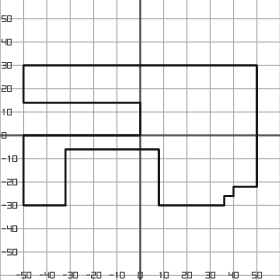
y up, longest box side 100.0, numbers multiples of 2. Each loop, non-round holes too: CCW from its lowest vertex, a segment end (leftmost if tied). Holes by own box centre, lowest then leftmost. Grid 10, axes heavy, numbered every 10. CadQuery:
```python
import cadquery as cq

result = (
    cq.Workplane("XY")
    .moveTo(-50.0, -30.0)
    .lineTo(-32.0, -30.0)
    .lineTo(-32.0, -6.0)
    .lineTo(8.0, -6.0)
    .lineTo(8.0, -30.0)
    .lineTo(36.0, -30.0)
    .lineTo(36.0, -26.0)
    .lineTo(40.0, -26.0)
    .lineTo(40.0, -22.0)
    .lineTo(50.0, -22.0)
    .lineTo(50.0, 30.0)
    .lineTo(-50.0, 30.0)
    .lineTo(-50.0, 14.0)
    .lineTo(0.0, 14.0)
    .lineTo(0.0, 0.0)
    .lineTo(-50.0, 0.0)
    .close()
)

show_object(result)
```